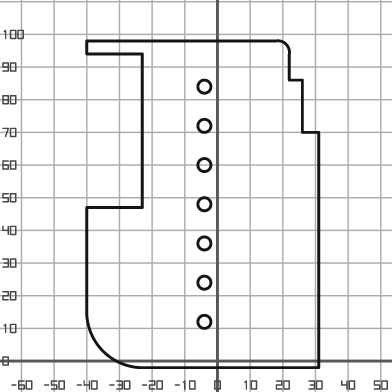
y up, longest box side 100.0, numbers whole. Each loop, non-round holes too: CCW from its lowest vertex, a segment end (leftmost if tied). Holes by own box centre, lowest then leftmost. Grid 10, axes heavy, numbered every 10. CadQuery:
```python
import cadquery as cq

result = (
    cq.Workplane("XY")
    .moveTo(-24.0, -2.0)
    .lineTo(31.0, -2.0)
    .lineTo(31.0, 70.0)
    .lineTo(26.0, 70.0)
    .lineTo(26.0, 86.0)
    .lineTo(22.0, 86.0)
    .lineTo(22.0, 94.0)
    .threePointArc((21.0, 97.0), (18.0, 98.0))
    .lineTo(-40.0, 98.0)
    .lineTo(-40.0, 94.0)
    .lineTo(-23.0, 94.0)
    .lineTo(-23.0, 47.0)
    .lineTo(-40.0, 47.0)
    .lineTo(-40.0, 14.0)
    .threePointArc((-35.0, 3.0), (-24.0, -2.0))
    .close()
    .moveTo(-4.0, 12.0)
    .circle(2.0)
    .moveTo(-4.0, 24.0)
    .circle(2.0)
    .moveTo(-4.0, 36.0)
    .circle(2.0)
    .moveTo(-4.0, 48.0)
    .circle(2.0)
    .moveTo(-4.0, 60.0)
    .circle(2.0)
    .moveTo(-4.0, 72.0)
    .circle(2.0)
    .moveTo(-4.0, 84.0)
    .circle(2.0)
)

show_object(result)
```